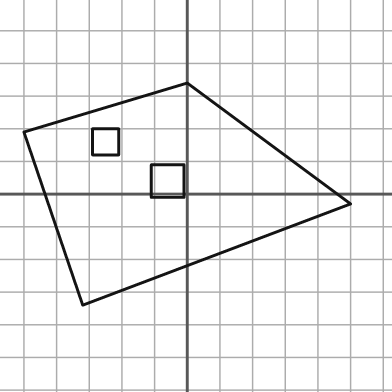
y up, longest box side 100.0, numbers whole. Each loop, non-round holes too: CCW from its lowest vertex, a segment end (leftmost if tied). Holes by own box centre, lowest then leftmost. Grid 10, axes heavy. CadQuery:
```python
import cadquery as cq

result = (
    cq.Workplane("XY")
    .moveTo(-32.0, -34.0)
    .lineTo(50.0, -3.0)
    .lineTo(0.0, 34.0)
    .lineTo(-50.0, 19.0)
    .close()
    .moveTo(-11.0, -1.0)
    .lineTo(-1.0, -1.0)
    .lineTo(-1.0, 9.0)
    .lineTo(-11.0, 9.0)
    .close()
    .moveTo(-29.0, 12.0)
    .lineTo(-21.0, 12.0)
    .lineTo(-21.0, 20.0)
    .lineTo(-29.0, 20.0)
    .close()
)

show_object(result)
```